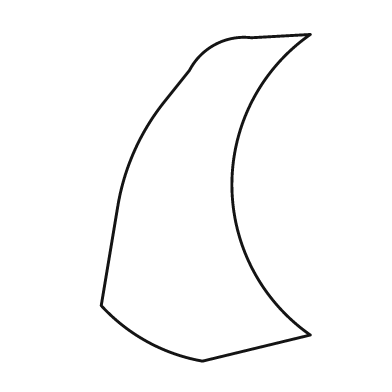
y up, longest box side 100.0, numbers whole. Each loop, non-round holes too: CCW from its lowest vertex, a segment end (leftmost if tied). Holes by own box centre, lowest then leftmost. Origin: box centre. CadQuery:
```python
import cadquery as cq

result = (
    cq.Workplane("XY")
    .moveTo(-1.0, -50.0)
    .lineTo(32.0, -42.0)
    .threePointArc((8.0, 4.0), (32.0, 50.0))
    .lineTo(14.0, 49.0)
    .threePointArc((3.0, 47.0), (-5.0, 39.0))
    .lineTo(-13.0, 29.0)
    .threePointArc((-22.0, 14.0), (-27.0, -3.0))
    .lineTo(-32.0, -33.0)
    .threePointArc((-18.0, -44.0), (-1.0, -50.0))
    .close()
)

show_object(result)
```